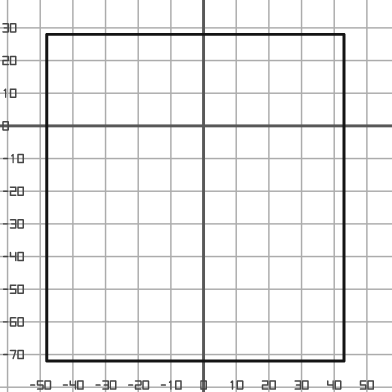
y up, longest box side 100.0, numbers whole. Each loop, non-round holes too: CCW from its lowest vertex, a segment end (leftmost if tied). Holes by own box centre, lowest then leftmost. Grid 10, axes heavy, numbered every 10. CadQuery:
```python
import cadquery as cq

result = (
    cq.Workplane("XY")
    .moveTo(-48.0, -72.0)
    .lineTo(43.0, -72.0)
    .lineTo(43.0, 28.0)
    .lineTo(-48.0, 28.0)
    .close()
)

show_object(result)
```